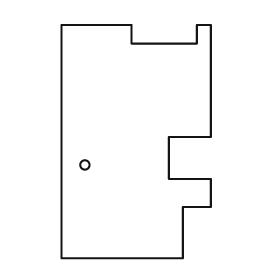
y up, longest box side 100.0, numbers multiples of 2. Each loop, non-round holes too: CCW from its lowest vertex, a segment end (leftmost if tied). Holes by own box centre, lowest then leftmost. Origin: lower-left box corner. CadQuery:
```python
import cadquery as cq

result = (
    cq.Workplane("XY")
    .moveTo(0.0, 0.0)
    .lineTo(52.0, 0.0)
    .lineTo(52.0, 22.0)
    .lineTo(64.0, 22.0)
    .lineTo(64.0, 34.0)
    .lineTo(46.0, 34.0)
    .lineTo(46.0, 52.0)
    .lineTo(64.0, 52.0)
    .lineTo(64.0, 100.0)
    .lineTo(58.0, 100.0)
    .lineTo(58.0, 92.0)
    .lineTo(30.0, 92.0)
    .lineTo(30.0, 100.0)
    .lineTo(0.0, 100.0)
    .close()
    .moveTo(10.0, 40.0)
    .circle(2.0)
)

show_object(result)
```